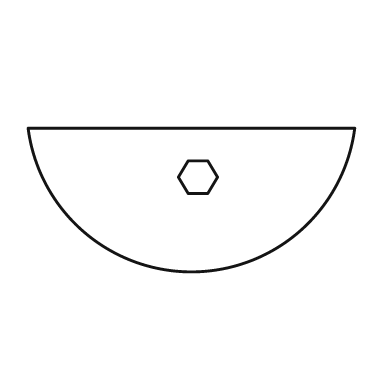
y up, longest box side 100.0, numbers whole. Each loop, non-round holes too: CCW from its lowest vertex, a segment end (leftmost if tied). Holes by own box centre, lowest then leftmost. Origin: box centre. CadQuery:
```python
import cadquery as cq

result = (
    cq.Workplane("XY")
    .moveTo(-50.0, 22.0)
    .threePointArc((0.0, -22.0), (50.0, 22.0))
    .close()
    .moveTo(-1.0, 2.0)
    .lineTo(5.0, 2.0)
    .lineTo(8.0, 7.0)
    .lineTo(5.0, 12.0)
    .lineTo(-1.0, 12.0)
    .lineTo(-4.0, 7.0)
    .close()
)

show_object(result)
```